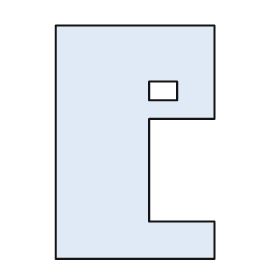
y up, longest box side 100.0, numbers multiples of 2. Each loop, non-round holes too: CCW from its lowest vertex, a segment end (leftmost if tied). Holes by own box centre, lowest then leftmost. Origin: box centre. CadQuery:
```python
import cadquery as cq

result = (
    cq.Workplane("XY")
    .moveTo(-34.0, -50.0)
    .lineTo(34.0, -50.0)
    .lineTo(34.0, -34.0)
    .lineTo(6.0, -34.0)
    .lineTo(6.0, 10.0)
    .lineTo(34.0, 10.0)
    .lineTo(34.0, 50.0)
    .lineTo(-34.0, 50.0)
    .close()
    .moveTo(6.0, 18.0)
    .lineTo(18.0, 18.0)
    .lineTo(18.0, 26.0)
    .lineTo(6.0, 26.0)
    .close()
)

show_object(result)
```